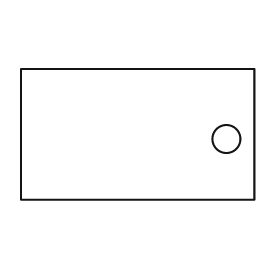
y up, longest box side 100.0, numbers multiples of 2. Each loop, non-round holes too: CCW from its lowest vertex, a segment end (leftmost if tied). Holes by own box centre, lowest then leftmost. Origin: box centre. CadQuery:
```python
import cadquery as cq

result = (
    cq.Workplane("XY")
    .moveTo(-50.0, -28.0)
    .lineTo(50.0, -28.0)
    .lineTo(50.0, 28.0)
    .lineTo(-50.0, 28.0)
    .close()
    .moveTo(38.0, -2.0)
    .circle(6.0)
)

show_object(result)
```